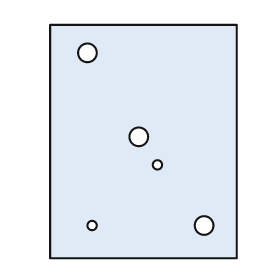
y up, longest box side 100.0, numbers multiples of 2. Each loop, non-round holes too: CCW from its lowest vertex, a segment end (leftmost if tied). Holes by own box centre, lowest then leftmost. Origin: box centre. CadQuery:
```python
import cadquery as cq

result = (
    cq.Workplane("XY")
    .moveTo(-40.0, -50.0)
    .lineTo(40.0, -50.0)
    .lineTo(40.0, 50.0)
    .lineTo(-40.0, 50.0)
    .close()
    .moveTo(-22.0, -36.0)
    .circle(2.0)
    .moveTo(26.0, -36.0)
    .circle(4.0)
    .moveTo(6.0, -10.0)
    .circle(2.0)
    .moveTo(-2.0, 2.0)
    .circle(4.0)
    .moveTo(-24.0, 38.0)
    .circle(4.0)
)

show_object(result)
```